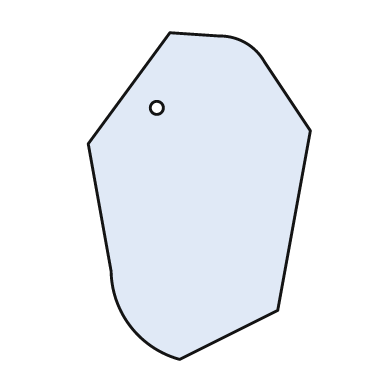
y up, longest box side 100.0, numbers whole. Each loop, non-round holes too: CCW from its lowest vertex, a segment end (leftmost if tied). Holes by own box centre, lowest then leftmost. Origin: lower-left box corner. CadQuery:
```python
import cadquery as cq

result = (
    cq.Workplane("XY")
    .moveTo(28.0, 0.0)
    .lineTo(58.0, 15.0)
    .lineTo(68.0, 70.0)
    .lineTo(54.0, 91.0)
    .threePointArc((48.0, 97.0), (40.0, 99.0))
    .lineTo(25.0, 100.0)
    .lineTo(0.0, 66.0)
    .lineTo(7.0, 27.0)
    .threePointArc((13.0, 10.0), (28.0, 0.0))
    .close()
    .moveTo(21.0, 77.0)
    .circle(2.0)
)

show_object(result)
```